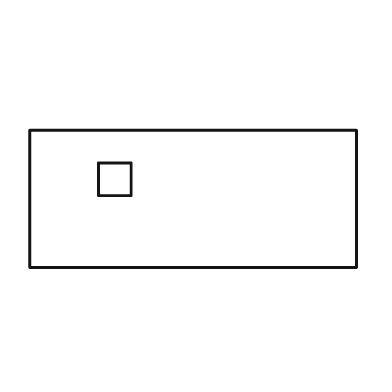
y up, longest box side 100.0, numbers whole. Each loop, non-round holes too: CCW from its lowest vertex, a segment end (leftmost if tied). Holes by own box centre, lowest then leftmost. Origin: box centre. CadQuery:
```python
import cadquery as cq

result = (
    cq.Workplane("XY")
    .moveTo(-50.0, -21.0)
    .lineTo(50.0, -21.0)
    .lineTo(50.0, 21.0)
    .lineTo(-50.0, 21.0)
    .close()
    .moveTo(-29.0, 1.0)
    .lineTo(-19.0, 1.0)
    .lineTo(-19.0, 11.0)
    .lineTo(-29.0, 11.0)
    .close()
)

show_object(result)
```